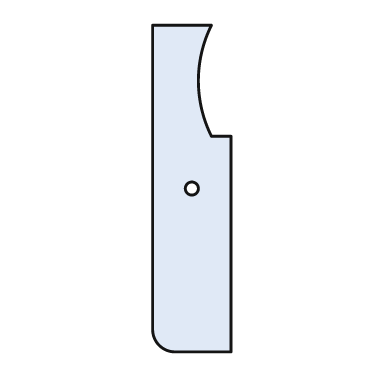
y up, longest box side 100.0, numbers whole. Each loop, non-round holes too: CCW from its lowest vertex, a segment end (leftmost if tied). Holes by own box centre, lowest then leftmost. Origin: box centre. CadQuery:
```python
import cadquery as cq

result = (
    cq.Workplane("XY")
    .moveTo(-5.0, -50.0)
    .lineTo(12.0, -50.0)
    .lineTo(12.0, 16.0)
    .lineTo(6.0, 16.0)
    .threePointArc((2.0, 33.0), (6.0, 50.0))
    .lineTo(-12.0, 50.0)
    .lineTo(-12.0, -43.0)
    .threePointArc((-10.0, -48.0), (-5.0, -50.0))
    .close()
    .moveTo(0.0, 0.0)
    .circle(2.0)
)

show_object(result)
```